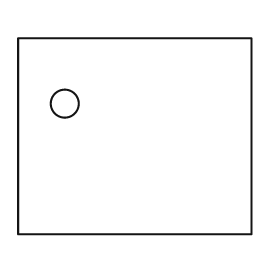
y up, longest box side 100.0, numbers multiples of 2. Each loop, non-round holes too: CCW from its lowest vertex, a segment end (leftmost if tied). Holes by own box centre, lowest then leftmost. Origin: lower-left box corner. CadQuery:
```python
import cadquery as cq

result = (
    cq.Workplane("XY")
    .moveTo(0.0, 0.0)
    .lineTo(100.0, 0.0)
    .lineTo(100.0, 84.0)
    .lineTo(0.0, 84.0)
    .close()
    .moveTo(20.0, 56.0)
    .circle(6.0)
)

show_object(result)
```